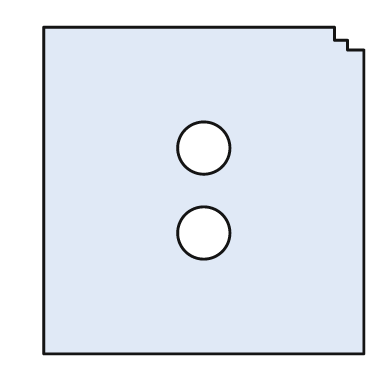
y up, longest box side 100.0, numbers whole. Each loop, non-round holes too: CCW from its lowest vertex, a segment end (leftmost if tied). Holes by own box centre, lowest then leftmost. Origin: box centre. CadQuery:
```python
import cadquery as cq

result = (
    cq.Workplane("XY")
    .moveTo(-49.0, -50.0)
    .lineTo(49.0, -50.0)
    .lineTo(49.0, 43.0)
    .lineTo(44.0, 43.0)
    .lineTo(44.0, 46.0)
    .lineTo(40.0, 46.0)
    .lineTo(40.0, 50.0)
    .lineTo(-49.0, 50.0)
    .close()
    .moveTo(0.0, -13.0)
    .circle(8.0)
    .moveTo(0.0, 13.0)
    .circle(8.0)
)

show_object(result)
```